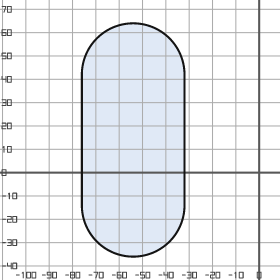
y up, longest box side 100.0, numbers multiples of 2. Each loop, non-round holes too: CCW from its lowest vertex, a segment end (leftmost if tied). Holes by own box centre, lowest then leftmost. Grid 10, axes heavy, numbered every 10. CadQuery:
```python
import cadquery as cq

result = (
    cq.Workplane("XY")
    .moveTo(-76.0, -14.0)
    .threePointArc((-54.0, -36.0), (-32.0, -14.0))
    .lineTo(-32.0, 42.0)
    .threePointArc((-54.0, 64.0), (-76.0, 42.0))
    .close()
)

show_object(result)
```